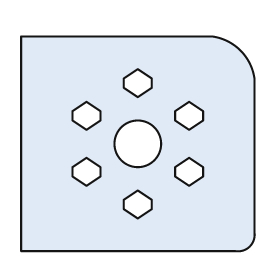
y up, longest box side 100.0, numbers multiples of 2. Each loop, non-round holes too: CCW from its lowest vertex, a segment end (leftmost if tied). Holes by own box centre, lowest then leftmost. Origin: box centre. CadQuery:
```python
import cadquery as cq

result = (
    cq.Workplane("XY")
    .moveTo(-50.0, -46.0)
    .lineTo(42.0, -46.0)
    .threePointArc((48.0, -44.0), (50.0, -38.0))
    .lineTo(50.0, 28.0)
    .threePointArc((44.0, 40.0), (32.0, 46.0))
    .lineTo(-50.0, 46.0)
    .close()
    .moveTo(0.0, -32.0)
    .lineTo(6.0, -28.0)
    .lineTo(6.0, -24.0)
    .lineTo(0.0, -20.0)
    .lineTo(-6.0, -24.0)
    .lineTo(-6.0, -28.0)
    .close()
    .moveTo(-22.0, -18.0)
    .lineTo(-16.0, -14.0)
    .lineTo(-16.0, -10.0)
    .lineTo(-22.0, -6.0)
    .lineTo(-28.0, -10.0)
    .lineTo(-28.0, -14.0)
    .close()
    .moveTo(22.0, -18.0)
    .lineTo(28.0, -14.0)
    .lineTo(28.0, -10.0)
    .lineTo(22.0, -6.0)
    .lineTo(16.0, -10.0)
    .lineTo(16.0, -14.0)
    .close()
    .moveTo(0.0, 0.0)
    .circle(10.0)
    .moveTo(-22.0, 6.0)
    .lineTo(-16.0, 10.0)
    .lineTo(-16.0, 14.0)
    .lineTo(-22.0, 18.0)
    .lineTo(-28.0, 14.0)
    .lineTo(-28.0, 10.0)
    .close()
    .moveTo(22.0, 6.0)
    .lineTo(28.0, 10.0)
    .lineTo(28.0, 14.0)
    .lineTo(22.0, 18.0)
    .lineTo(16.0, 14.0)
    .lineTo(16.0, 10.0)
    .close()
    .moveTo(0.0, 20.0)
    .lineTo(6.0, 24.0)
    .lineTo(6.0, 28.0)
    .lineTo(0.0, 32.0)
    .lineTo(-6.0, 28.0)
    .lineTo(-6.0, 24.0)
    .close()
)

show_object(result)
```